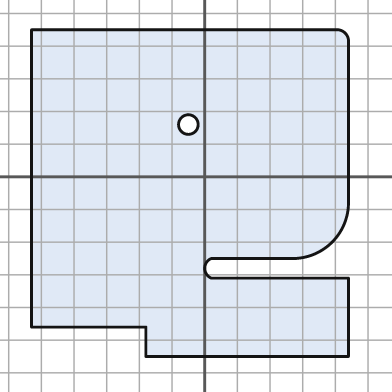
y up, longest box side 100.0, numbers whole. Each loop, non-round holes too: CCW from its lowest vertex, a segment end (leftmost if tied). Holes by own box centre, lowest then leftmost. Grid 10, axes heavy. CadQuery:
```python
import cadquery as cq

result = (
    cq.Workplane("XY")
    .moveTo(-18.0, -55.0)
    .lineTo(44.0, -55.0)
    .lineTo(44.0, -31.0)
    .lineTo(2.0, -31.0)
    .threePointArc((0.0, -28.0), (2.0, -25.0))
    .lineTo(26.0, -25.0)
    .threePointArc((39.0, -20.0), (44.0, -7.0))
    .lineTo(44.0, 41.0)
    .threePointArc((43.0, 44.0), (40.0, 45.0))
    .lineTo(-53.0, 45.0)
    .lineTo(-53.0, -46.0)
    .lineTo(-18.0, -46.0)
    .close()
    .moveTo(-5.0, 16.0)
    .circle(3.0)
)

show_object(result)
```